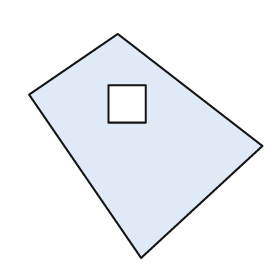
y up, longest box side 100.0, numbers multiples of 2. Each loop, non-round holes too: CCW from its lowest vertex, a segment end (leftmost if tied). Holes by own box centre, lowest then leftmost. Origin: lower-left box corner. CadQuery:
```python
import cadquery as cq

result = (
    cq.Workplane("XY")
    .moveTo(48.0, 0.0)
    .lineTo(100.0, 48.0)
    .lineTo(38.0, 96.0)
    .lineTo(0.0, 70.0)
    .close()
    .moveTo(34.0, 58.0)
    .lineTo(50.0, 58.0)
    .lineTo(50.0, 74.0)
    .lineTo(34.0, 74.0)
    .close()
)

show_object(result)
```